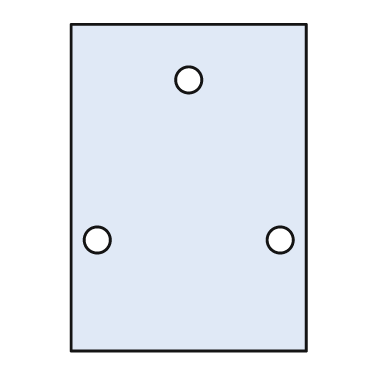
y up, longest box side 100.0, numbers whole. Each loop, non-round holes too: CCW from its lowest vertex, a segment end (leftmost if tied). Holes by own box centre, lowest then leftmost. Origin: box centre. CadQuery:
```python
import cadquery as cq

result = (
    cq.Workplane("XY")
    .moveTo(-36.0, -50.0)
    .lineTo(36.0, -50.0)
    .lineTo(36.0, 50.0)
    .lineTo(-36.0, 50.0)
    .close()
    .moveTo(-28.0, -16.0)
    .circle(4.0)
    .moveTo(28.0, -16.0)
    .circle(4.0)
    .moveTo(0.0, 33.0)
    .circle(4.0)
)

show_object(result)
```